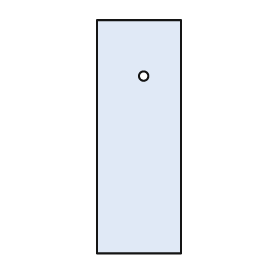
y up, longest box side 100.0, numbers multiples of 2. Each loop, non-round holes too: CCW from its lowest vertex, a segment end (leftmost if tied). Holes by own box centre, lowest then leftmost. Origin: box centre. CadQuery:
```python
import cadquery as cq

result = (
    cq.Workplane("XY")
    .moveTo(-18.0, -50.0)
    .lineTo(18.0, -50.0)
    .lineTo(18.0, 50.0)
    .lineTo(-18.0, 50.0)
    .close()
    .moveTo(2.0, 26.0)
    .circle(2.0)
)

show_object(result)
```